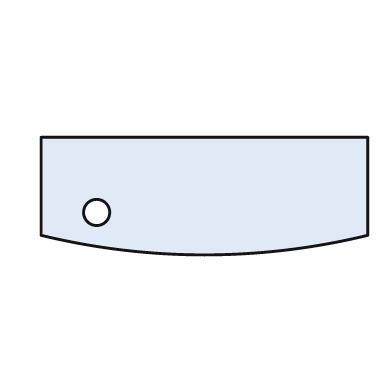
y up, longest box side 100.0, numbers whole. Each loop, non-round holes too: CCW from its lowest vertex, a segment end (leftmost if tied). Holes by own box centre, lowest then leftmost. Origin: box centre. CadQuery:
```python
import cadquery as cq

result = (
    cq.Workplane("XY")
    .moveTo(-50.0, -12.0)
    .threePointArc((0.0, -18.0), (50.0, -12.0))
    .lineTo(50.0, 18.0)
    .lineTo(-50.0, 18.0)
    .close()
    .moveTo(-33.0, -5.0)
    .circle(4.0)
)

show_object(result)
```